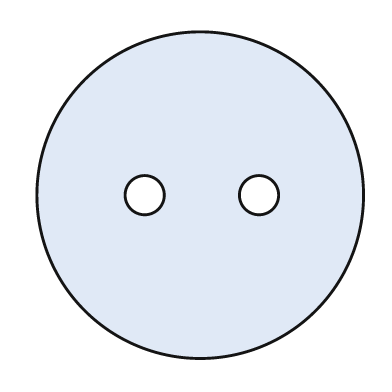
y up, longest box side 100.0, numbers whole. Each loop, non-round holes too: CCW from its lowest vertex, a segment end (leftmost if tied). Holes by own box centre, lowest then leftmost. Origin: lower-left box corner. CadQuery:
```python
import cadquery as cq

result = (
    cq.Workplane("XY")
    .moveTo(50.0, 50.0)
    .circle(50.0)
    .moveTo(33.0, 50.0)
    .circle(6.0)
    .moveTo(68.0, 50.0)
    .circle(6.0)
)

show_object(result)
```